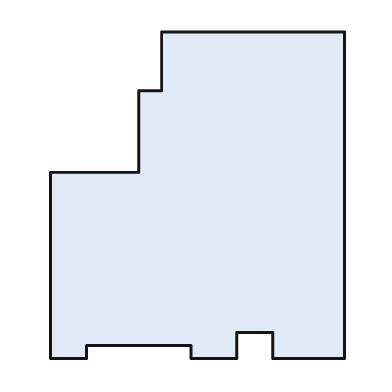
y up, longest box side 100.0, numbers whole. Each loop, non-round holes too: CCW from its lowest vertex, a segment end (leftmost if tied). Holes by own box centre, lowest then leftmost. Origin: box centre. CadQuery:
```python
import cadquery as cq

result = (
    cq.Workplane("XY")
    .moveTo(-45.0, -50.0)
    .lineTo(-34.0, -50.0)
    .lineTo(-34.0, -46.0)
    .lineTo(-2.0, -46.0)
    .lineTo(-2.0, -50.0)
    .lineTo(12.0, -50.0)
    .lineTo(12.0, -42.0)
    .lineTo(23.0, -42.0)
    .lineTo(23.0, -50.0)
    .lineTo(45.0, -50.0)
    .lineTo(45.0, 50.0)
    .lineTo(-11.0, 50.0)
    .lineTo(-11.0, 32.0)
    .lineTo(-18.0, 32.0)
    .lineTo(-18.0, 7.0)
    .lineTo(-45.0, 7.0)
    .close()
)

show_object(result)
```